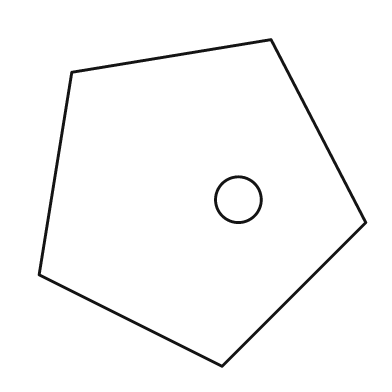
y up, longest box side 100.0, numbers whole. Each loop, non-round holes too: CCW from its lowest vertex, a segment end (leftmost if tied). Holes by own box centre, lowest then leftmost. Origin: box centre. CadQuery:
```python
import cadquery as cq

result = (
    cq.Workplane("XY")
    .moveTo(6.0, -50.0)
    .lineTo(50.0, -6.0)
    .lineTo(21.0, 50.0)
    .lineTo(-40.0, 40.0)
    .lineTo(-50.0, -22.0)
    .close()
    .moveTo(11.0, 1.0)
    .circle(7.0)
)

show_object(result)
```